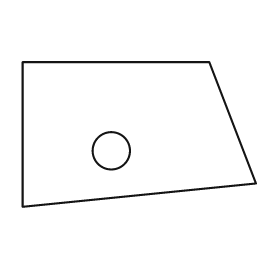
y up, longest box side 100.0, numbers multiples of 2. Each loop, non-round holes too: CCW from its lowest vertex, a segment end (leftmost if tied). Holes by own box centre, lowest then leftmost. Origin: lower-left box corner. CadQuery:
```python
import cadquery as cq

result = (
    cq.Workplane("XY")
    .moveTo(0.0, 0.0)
    .lineTo(100.0, 10.0)
    .lineTo(80.0, 62.0)
    .lineTo(0.0, 62.0)
    .close()
    .moveTo(38.0, 24.0)
    .circle(8.0)
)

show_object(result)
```